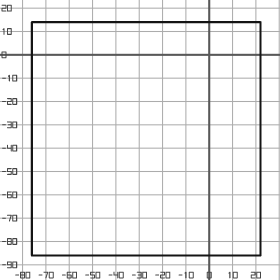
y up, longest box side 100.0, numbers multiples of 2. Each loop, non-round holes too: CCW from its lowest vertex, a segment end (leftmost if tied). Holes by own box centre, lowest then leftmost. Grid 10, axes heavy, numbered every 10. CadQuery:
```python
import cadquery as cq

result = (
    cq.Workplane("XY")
    .moveTo(-76.0, -86.0)
    .lineTo(22.0, -86.0)
    .lineTo(22.0, 14.0)
    .lineTo(-76.0, 14.0)
    .close()
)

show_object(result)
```